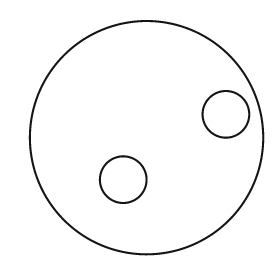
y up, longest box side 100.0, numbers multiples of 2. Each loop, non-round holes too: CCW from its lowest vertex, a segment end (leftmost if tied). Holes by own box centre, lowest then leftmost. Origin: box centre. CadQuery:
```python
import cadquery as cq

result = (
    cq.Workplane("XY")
    .moveTo(0.0, 0.0)
    .circle(50.0)
    .moveTo(-10.0, -18.0)
    .circle(10.0)
    .moveTo(34.0, 10.0)
    .circle(10.0)
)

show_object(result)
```